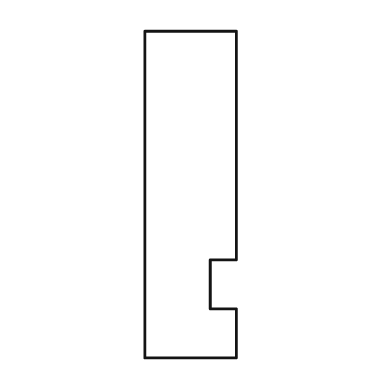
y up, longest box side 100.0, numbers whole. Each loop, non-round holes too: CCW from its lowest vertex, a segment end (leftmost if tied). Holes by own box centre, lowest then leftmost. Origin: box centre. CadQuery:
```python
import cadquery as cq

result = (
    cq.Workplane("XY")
    .moveTo(-14.0, -50.0)
    .lineTo(14.0, -50.0)
    .lineTo(14.0, -35.0)
    .lineTo(6.0, -35.0)
    .lineTo(6.0, -20.0)
    .lineTo(14.0, -20.0)
    .lineTo(14.0, 50.0)
    .lineTo(-14.0, 50.0)
    .close()
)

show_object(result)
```